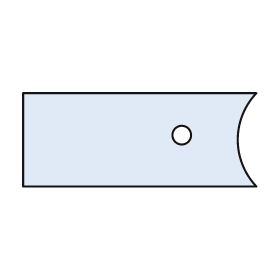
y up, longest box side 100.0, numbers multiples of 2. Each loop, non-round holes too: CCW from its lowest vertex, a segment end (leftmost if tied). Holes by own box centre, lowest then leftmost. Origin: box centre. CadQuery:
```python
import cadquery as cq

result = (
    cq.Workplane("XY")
    .moveTo(-50.0, -20.0)
    .lineTo(50.0, -20.0)
    .threePointArc((42.0, 0.0), (50.0, 20.0))
    .lineTo(-50.0, 20.0)
    .close()
    .moveTo(18.0, 2.0)
    .circle(4.0)
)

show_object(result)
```